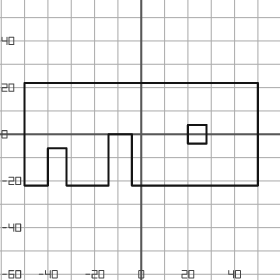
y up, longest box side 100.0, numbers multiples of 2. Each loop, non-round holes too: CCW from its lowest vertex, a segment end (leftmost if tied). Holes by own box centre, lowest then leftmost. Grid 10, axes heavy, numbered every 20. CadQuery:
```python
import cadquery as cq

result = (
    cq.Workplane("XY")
    .moveTo(-50.0, -22.0)
    .lineTo(-40.0, -22.0)
    .lineTo(-40.0, -6.0)
    .lineTo(-32.0, -6.0)
    .lineTo(-32.0, -22.0)
    .lineTo(-14.0, -22.0)
    .lineTo(-14.0, 0.0)
    .lineTo(-4.0, 0.0)
    .lineTo(-4.0, -22.0)
    .lineTo(50.0, -22.0)
    .lineTo(50.0, 22.0)
    .lineTo(-50.0, 22.0)
    .close()
    .moveTo(20.0, -4.0)
    .lineTo(28.0, -4.0)
    .lineTo(28.0, 4.0)
    .lineTo(20.0, 4.0)
    .close()
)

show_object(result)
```